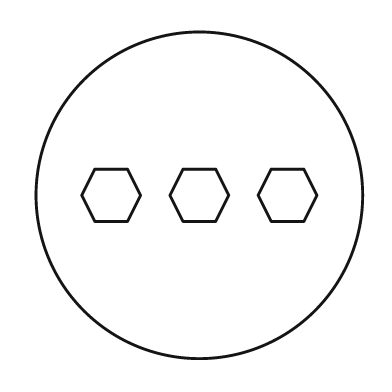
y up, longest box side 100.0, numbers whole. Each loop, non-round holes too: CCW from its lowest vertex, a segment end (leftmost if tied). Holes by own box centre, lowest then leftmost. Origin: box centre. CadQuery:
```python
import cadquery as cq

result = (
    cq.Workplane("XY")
    .moveTo(0.0, 0.0)
    .circle(50.0)
    .moveTo(-32.0, -8.0)
    .lineTo(-22.0, -8.0)
    .lineTo(-18.0, 0.0)
    .lineTo(-22.0, 8.0)
    .lineTo(-32.0, 8.0)
    .lineTo(-36.0, 0.0)
    .close()
    .moveTo(-5.0, -8.0)
    .lineTo(5.0, -8.0)
    .lineTo(9.0, 0.0)
    .lineTo(5.0, 8.0)
    .lineTo(-5.0, 8.0)
    .lineTo(-9.0, 0.0)
    .close()
    .moveTo(22.0, -8.0)
    .lineTo(32.0, -8.0)
    .lineTo(36.0, 0.0)
    .lineTo(32.0, 8.0)
    .lineTo(22.0, 8.0)
    .lineTo(18.0, 0.0)
    .close()
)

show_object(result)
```